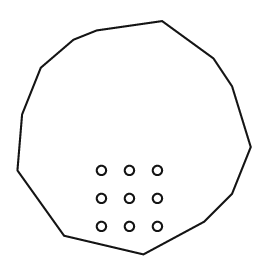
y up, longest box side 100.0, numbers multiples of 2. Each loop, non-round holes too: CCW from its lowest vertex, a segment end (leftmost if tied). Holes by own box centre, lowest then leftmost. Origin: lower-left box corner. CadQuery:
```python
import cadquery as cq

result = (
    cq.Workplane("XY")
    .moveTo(54.0, 0.0)
    .lineTo(80.0, 14.0)
    .lineTo(92.0, 26.0)
    .lineTo(100.0, 46.0)
    .lineTo(92.0, 72.0)
    .lineTo(84.0, 84.0)
    .lineTo(62.0, 100.0)
    .lineTo(34.0, 96.0)
    .lineTo(24.0, 92.0)
    .lineTo(10.0, 80.0)
    .lineTo(2.0, 60.0)
    .lineTo(0.0, 36.0)
    .lineTo(20.0, 8.0)
    .close()
    .moveTo(36.0, 12.0)
    .circle(2.0)
    .moveTo(48.0, 12.0)
    .circle(2.0)
    .moveTo(60.0, 12.0)
    .circle(2.0)
    .moveTo(36.0, 24.0)
    .circle(2.0)
    .moveTo(48.0, 24.0)
    .circle(2.0)
    .moveTo(60.0, 24.0)
    .circle(2.0)
    .moveTo(36.0, 36.0)
    .circle(2.0)
    .moveTo(48.0, 36.0)
    .circle(2.0)
    .moveTo(60.0, 36.0)
    .circle(2.0)
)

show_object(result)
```